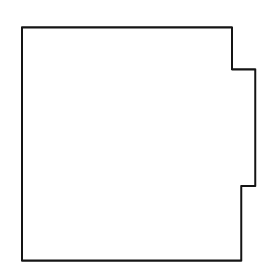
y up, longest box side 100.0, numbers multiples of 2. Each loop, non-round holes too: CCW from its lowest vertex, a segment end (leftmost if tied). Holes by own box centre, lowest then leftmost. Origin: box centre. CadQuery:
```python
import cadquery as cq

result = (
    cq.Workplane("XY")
    .moveTo(-50.0, -50.0)
    .lineTo(44.0, -50.0)
    .lineTo(44.0, -18.0)
    .lineTo(50.0, -18.0)
    .lineTo(50.0, 32.0)
    .lineTo(40.0, 32.0)
    .lineTo(40.0, 50.0)
    .lineTo(-50.0, 50.0)
    .close()
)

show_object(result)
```